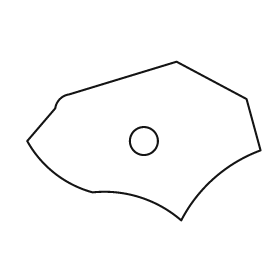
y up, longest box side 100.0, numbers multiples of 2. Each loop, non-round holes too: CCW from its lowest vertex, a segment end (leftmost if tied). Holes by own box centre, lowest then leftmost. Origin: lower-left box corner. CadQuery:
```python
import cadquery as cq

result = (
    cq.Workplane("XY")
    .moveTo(66.0, 0.0)
    .threePointArc((80.0, 18.0), (100.0, 30.0))
    .lineTo(94.0, 52.0)
    .lineTo(64.0, 68.0)
    .lineTo(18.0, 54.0)
    .threePointArc((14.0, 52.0), (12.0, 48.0))
    .lineTo(0.0, 34.0)
    .threePointArc((12.0, 20.0), (28.0, 12.0))
    .threePointArc((48.0, 10.0), (66.0, 0.0))
    .close()
    .moveTo(50.0, 34.0)
    .circle(6.0)
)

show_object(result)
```